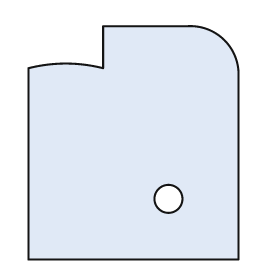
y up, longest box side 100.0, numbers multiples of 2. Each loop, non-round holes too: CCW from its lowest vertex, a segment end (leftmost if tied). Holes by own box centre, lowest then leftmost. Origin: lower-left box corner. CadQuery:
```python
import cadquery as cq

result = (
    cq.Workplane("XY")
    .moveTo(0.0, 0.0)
    .lineTo(90.0, 0.0)
    .lineTo(90.0, 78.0)
    .threePointArc((84.0, 94.0), (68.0, 100.0))
    .lineTo(32.0, 100.0)
    .lineTo(32.0, 82.0)
    .threePointArc((16.0, 84.0), (0.0, 82.0))
    .close()
    .moveTo(60.0, 26.0)
    .circle(6.0)
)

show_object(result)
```